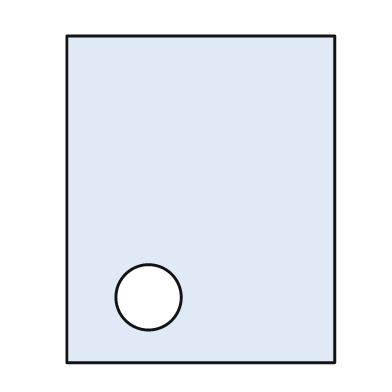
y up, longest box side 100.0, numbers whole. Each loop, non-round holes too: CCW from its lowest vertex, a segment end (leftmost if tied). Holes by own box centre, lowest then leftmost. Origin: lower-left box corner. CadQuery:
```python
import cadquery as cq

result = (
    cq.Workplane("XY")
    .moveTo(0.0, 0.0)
    .lineTo(82.0, 0.0)
    .lineTo(82.0, 100.0)
    .lineTo(0.0, 100.0)
    .close()
    .moveTo(25.0, 20.0)
    .circle(10.0)
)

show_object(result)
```